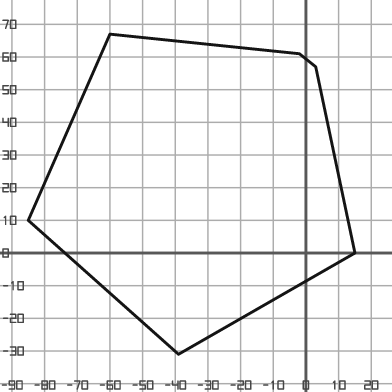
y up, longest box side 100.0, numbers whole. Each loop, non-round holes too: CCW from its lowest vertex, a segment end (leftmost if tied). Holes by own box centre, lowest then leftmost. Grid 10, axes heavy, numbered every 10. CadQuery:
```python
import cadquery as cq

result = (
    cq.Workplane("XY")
    .moveTo(-39.0, -31.0)
    .lineTo(15.0, 0.0)
    .lineTo(3.0, 57.0)
    .lineTo(-2.0, 61.0)
    .lineTo(-60.0, 67.0)
    .lineTo(-85.0, 10.0)
    .close()
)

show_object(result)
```